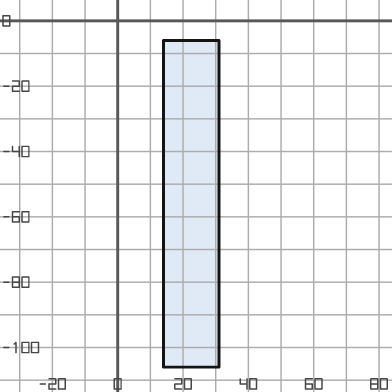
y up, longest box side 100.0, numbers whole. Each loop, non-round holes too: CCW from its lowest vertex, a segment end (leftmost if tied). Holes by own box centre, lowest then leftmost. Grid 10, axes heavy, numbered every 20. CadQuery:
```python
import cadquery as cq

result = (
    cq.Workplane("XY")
    .moveTo(14.0, -106.0)
    .lineTo(31.0, -106.0)
    .lineTo(31.0, -6.0)
    .lineTo(14.0, -6.0)
    .close()
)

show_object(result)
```